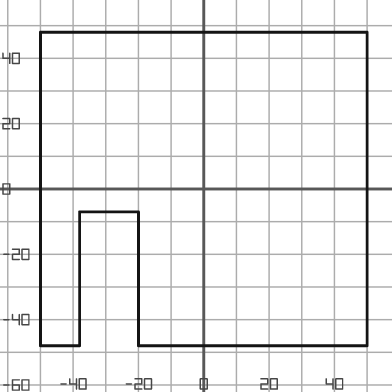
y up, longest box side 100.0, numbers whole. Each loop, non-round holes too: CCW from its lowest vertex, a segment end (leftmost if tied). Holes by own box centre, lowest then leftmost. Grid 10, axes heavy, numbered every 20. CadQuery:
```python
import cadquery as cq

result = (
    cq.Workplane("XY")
    .moveTo(-50.0, -48.0)
    .lineTo(-38.0, -48.0)
    .lineTo(-38.0, -7.0)
    .lineTo(-20.0, -7.0)
    .lineTo(-20.0, -48.0)
    .lineTo(50.0, -48.0)
    .lineTo(50.0, 48.0)
    .lineTo(-50.0, 48.0)
    .close()
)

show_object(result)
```